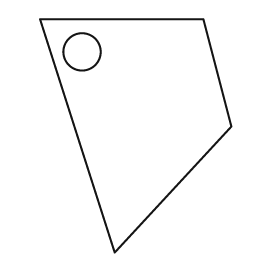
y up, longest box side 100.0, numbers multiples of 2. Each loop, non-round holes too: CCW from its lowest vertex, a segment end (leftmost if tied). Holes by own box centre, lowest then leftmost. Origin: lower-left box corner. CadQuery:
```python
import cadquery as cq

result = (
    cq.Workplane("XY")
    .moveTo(32.0, 0.0)
    .lineTo(82.0, 54.0)
    .lineTo(70.0, 100.0)
    .lineTo(0.0, 100.0)
    .close()
    .moveTo(18.0, 86.0)
    .circle(8.0)
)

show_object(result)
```